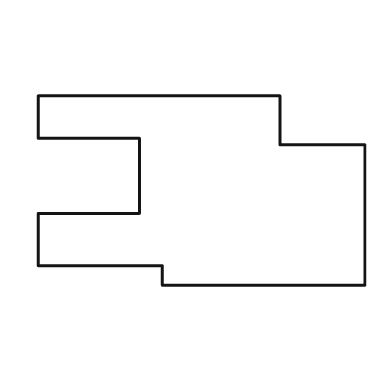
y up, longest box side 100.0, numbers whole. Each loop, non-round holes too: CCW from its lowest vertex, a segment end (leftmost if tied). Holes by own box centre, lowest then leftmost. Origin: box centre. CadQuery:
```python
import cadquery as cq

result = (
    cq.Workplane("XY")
    .moveTo(-12.0, -29.0)
    .lineTo(50.0, -29.0)
    .lineTo(50.0, 14.0)
    .lineTo(24.0, 14.0)
    .lineTo(24.0, 29.0)
    .lineTo(-50.0, 29.0)
    .lineTo(-50.0, 16.0)
    .lineTo(-19.0, 16.0)
    .lineTo(-19.0, -7.0)
    .lineTo(-50.0, -7.0)
    .lineTo(-50.0, -23.0)
    .lineTo(-12.0, -23.0)
    .close()
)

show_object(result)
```